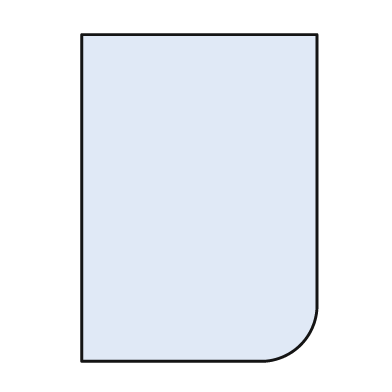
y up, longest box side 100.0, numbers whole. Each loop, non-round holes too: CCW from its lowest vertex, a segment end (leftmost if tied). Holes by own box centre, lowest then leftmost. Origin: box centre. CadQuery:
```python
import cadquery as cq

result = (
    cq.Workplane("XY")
    .moveTo(-36.0, -50.0)
    .lineTo(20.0, -50.0)
    .threePointArc((31.0, -45.0), (36.0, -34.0))
    .lineTo(36.0, 50.0)
    .lineTo(-36.0, 50.0)
    .close()
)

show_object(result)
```